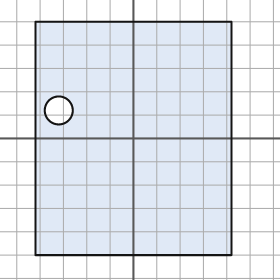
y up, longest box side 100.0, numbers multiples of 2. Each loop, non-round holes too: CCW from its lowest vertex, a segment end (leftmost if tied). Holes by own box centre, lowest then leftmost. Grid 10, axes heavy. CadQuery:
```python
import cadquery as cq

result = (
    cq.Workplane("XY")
    .moveTo(-42.0, -50.0)
    .lineTo(42.0, -50.0)
    .lineTo(42.0, 50.0)
    .lineTo(-42.0, 50.0)
    .close()
    .moveTo(-32.0, 12.0)
    .circle(6.0)
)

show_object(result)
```